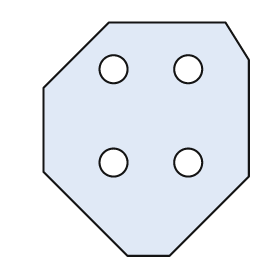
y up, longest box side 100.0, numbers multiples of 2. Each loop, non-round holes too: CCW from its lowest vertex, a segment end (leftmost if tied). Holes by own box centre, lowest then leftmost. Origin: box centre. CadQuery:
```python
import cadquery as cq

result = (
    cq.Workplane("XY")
    .moveTo(-8.0, -50.0)
    .lineTo(10.0, -50.0)
    .lineTo(44.0, -16.0)
    .lineTo(44.0, 34.0)
    .lineTo(34.0, 50.0)
    .lineTo(-16.0, 50.0)
    .lineTo(-44.0, 22.0)
    .lineTo(-44.0, -14.0)
    .close()
    .moveTo(-14.0, -10.0)
    .circle(6.0)
    .moveTo(18.0, -10.0)
    .circle(6.0)
    .moveTo(-14.0, 30.0)
    .circle(6.0)
    .moveTo(18.0, 30.0)
    .circle(6.0)
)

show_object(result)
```